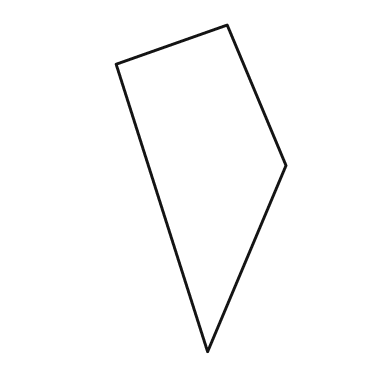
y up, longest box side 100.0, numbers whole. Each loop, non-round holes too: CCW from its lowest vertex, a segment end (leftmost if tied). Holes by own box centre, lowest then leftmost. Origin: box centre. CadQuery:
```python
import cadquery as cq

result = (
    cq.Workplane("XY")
    .moveTo(2.0, -50.0)
    .lineTo(26.0, 7.0)
    .lineTo(8.0, 50.0)
    .lineTo(-26.0, 38.0)
    .close()
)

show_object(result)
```